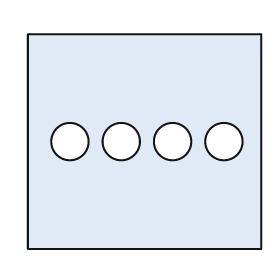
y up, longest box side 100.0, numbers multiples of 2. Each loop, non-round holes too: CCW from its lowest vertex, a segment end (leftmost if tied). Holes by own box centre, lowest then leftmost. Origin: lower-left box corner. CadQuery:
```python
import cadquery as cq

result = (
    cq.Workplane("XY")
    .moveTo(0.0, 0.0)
    .lineTo(100.0, 0.0)
    .lineTo(100.0, 92.0)
    .lineTo(0.0, 92.0)
    .close()
    .moveTo(18.0, 46.0)
    .circle(8.0)
    .moveTo(40.0, 46.0)
    .circle(8.0)
    .moveTo(62.0, 46.0)
    .circle(8.0)
    .moveTo(84.0, 46.0)
    .circle(8.0)
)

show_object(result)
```